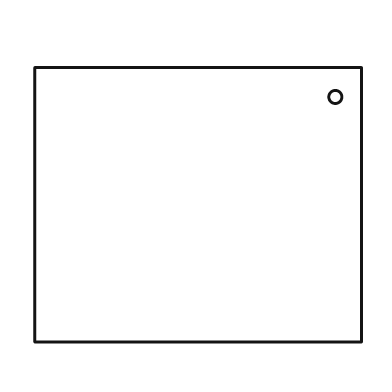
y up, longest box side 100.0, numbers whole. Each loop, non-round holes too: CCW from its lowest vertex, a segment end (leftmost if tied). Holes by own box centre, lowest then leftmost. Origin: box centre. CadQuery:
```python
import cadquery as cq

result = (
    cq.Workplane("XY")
    .moveTo(-50.0, -42.0)
    .lineTo(50.0, -42.0)
    .lineTo(50.0, 42.0)
    .lineTo(-50.0, 42.0)
    .close()
    .moveTo(42.0, 33.0)
    .circle(2.0)
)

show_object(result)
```